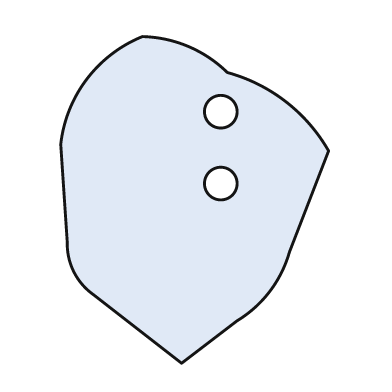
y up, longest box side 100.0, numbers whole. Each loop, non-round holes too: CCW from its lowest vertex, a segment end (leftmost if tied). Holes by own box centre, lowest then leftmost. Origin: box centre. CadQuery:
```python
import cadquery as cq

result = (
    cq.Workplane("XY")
    .moveTo(-4.0, -50.0)
    .lineTo(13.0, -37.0)
    .threePointArc((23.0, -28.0), (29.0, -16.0))
    .lineTo(41.0, 15.0)
    .threePointArc((28.0, 30.0), (10.0, 39.0))
    .threePointArc((-2.0, 47.0), (-16.0, 50.0))
    .threePointArc((-33.0, 37.0), (-41.0, 17.0))
    .lineTo(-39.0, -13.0)
    .threePointArc((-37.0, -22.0), (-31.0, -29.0))
    .close()
    .moveTo(8.0, 5.0)
    .circle(5.0)
    .moveTo(8.0, 27.0)
    .circle(5.0)
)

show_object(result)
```